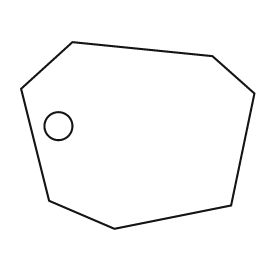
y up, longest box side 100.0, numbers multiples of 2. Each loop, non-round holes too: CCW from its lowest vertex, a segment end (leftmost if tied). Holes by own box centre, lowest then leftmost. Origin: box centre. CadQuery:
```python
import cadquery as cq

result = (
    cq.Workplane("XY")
    .moveTo(-10.0, -40.0)
    .lineTo(40.0, -30.0)
    .lineTo(50.0, 18.0)
    .lineTo(32.0, 34.0)
    .lineTo(-28.0, 40.0)
    .lineTo(-50.0, 20.0)
    .lineTo(-38.0, -28.0)
    .close()
    .moveTo(-34.0, 4.0)
    .circle(6.0)
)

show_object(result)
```